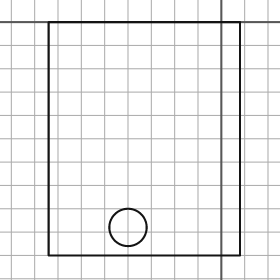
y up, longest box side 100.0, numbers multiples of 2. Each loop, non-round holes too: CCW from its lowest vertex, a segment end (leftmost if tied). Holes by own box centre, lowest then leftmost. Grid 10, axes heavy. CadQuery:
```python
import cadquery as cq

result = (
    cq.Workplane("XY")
    .moveTo(-74.0, -100.0)
    .lineTo(8.0, -100.0)
    .lineTo(8.0, 0.0)
    .lineTo(-74.0, 0.0)
    .close()
    .moveTo(-40.0, -88.0)
    .circle(8.0)
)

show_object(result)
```